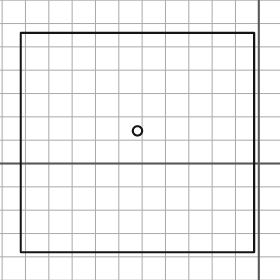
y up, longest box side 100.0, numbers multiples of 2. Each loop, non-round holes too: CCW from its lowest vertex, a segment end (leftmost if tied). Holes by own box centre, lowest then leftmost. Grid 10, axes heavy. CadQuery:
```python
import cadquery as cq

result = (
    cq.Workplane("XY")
    .moveTo(-102.0, -38.0)
    .lineTo(-2.0, -38.0)
    .lineTo(-2.0, 56.0)
    .lineTo(-102.0, 56.0)
    .close()
    .moveTo(-52.0, 14.0)
    .circle(2.0)
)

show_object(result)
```